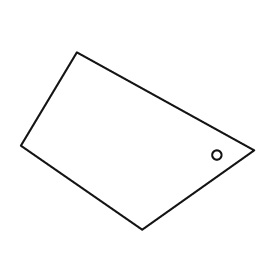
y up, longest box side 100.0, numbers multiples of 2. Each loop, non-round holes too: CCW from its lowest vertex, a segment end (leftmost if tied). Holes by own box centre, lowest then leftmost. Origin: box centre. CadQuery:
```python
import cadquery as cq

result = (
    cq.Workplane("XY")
    .moveTo(2.0, -38.0)
    .lineTo(50.0, -4.0)
    .lineTo(-26.0, 38.0)
    .lineTo(-50.0, -2.0)
    .close()
    .moveTo(34.0, -6.0)
    .circle(2.0)
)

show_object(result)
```